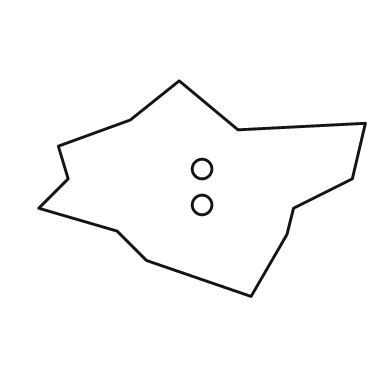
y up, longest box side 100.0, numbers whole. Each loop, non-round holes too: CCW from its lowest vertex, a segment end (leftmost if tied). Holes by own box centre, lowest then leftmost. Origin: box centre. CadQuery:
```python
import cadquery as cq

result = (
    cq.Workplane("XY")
    .moveTo(15.0, -33.0)
    .lineTo(26.0, -14.0)
    .lineTo(28.0, -6.0)
    .lineTo(46.0, 3.0)
    .lineTo(50.0, 20.0)
    .lineTo(11.0, 18.0)
    .lineTo(-7.0, 33.0)
    .lineTo(-22.0, 21.0)
    .lineTo(-44.0, 13.0)
    .lineTo(-41.0, 3.0)
    .lineTo(-50.0, -6.0)
    .lineTo(-26.0, -13.0)
    .lineTo(-17.0, -22.0)
    .close()
    .moveTo(0.0, -5.0)
    .circle(3.0)
    .moveTo(0.0, 6.0)
    .circle(3.0)
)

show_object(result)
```